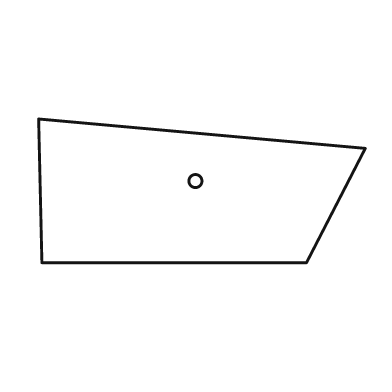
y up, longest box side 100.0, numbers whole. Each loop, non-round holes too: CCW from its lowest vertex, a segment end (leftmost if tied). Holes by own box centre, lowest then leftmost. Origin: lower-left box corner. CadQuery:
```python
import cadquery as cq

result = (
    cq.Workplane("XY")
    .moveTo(1.0, 0.0)
    .lineTo(82.0, 0.0)
    .lineTo(100.0, 35.0)
    .lineTo(0.0, 44.0)
    .close()
    .moveTo(48.0, 25.0)
    .circle(2.0)
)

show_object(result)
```